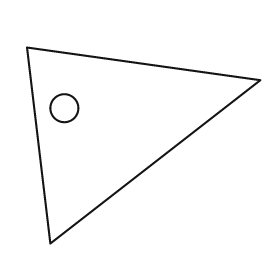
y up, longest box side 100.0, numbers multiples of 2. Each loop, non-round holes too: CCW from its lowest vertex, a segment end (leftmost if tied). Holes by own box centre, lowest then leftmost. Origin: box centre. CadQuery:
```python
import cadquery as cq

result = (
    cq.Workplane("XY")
    .moveTo(-40.0, -42.0)
    .lineTo(50.0, 28.0)
    .lineTo(-50.0, 42.0)
    .close()
    .moveTo(-34.0, 16.0)
    .circle(6.0)
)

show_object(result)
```